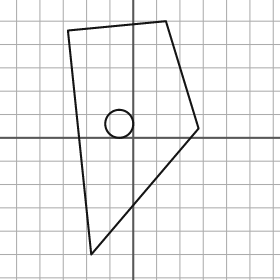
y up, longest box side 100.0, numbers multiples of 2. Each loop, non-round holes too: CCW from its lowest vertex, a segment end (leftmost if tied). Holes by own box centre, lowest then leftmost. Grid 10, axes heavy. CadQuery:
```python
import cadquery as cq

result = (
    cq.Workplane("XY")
    .moveTo(-18.0, -50.0)
    .lineTo(28.0, 4.0)
    .lineTo(14.0, 50.0)
    .lineTo(-28.0, 46.0)
    .close()
    .moveTo(-6.0, 6.0)
    .circle(6.0)
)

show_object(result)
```